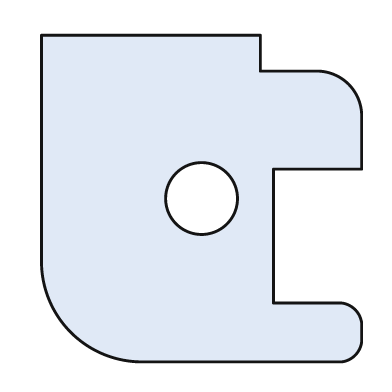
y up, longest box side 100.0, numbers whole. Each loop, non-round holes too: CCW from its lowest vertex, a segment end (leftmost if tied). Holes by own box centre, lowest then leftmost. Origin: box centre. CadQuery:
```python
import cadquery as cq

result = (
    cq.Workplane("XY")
    .moveTo(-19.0, -50.0)
    .lineTo(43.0, -50.0)
    .threePointArc((47.0, -48.0), (49.0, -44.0))
    .lineTo(49.0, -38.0)
    .threePointArc((47.0, -34.0), (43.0, -32.0))
    .lineTo(22.0, -32.0)
    .lineTo(22.0, 9.0)
    .lineTo(49.0, 9.0)
    .lineTo(49.0, 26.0)
    .threePointArc((45.0, 35.0), (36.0, 39.0))
    .lineTo(18.0, 39.0)
    .lineTo(18.0, 50.0)
    .lineTo(-49.0, 50.0)
    .lineTo(-49.0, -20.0)
    .threePointArc((-40.0, -41.0), (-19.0, -50.0))
    .close()
    .moveTo(0.0, 0.0)
    .circle(11.0)
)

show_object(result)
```